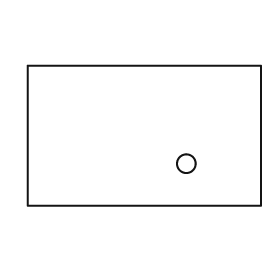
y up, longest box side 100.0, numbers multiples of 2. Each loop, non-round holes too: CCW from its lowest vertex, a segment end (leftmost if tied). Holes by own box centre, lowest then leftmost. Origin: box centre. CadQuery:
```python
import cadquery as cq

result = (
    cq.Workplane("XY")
    .moveTo(-50.0, -30.0)
    .lineTo(50.0, -30.0)
    .lineTo(50.0, 30.0)
    .lineTo(-50.0, 30.0)
    .close()
    .moveTo(18.0, -12.0)
    .circle(4.0)
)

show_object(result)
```